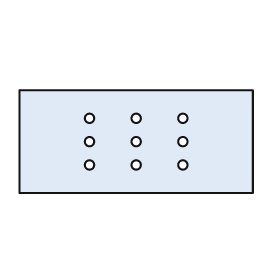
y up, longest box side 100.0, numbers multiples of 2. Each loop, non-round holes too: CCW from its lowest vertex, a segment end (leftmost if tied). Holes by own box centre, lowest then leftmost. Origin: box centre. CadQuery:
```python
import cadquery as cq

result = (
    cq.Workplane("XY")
    .moveTo(-50.0, -22.0)
    .lineTo(50.0, -22.0)
    .lineTo(50.0, 22.0)
    .lineTo(-50.0, 22.0)
    .close()
    .moveTo(-20.0, -10.0)
    .circle(2.0)
    .moveTo(0.0, -10.0)
    .circle(2.0)
    .moveTo(20.0, -10.0)
    .circle(2.0)
    .moveTo(-20.0, 0.0)
    .circle(2.0)
    .moveTo(0.0, 0.0)
    .circle(2.0)
    .moveTo(20.0, 0.0)
    .circle(2.0)
    .moveTo(-20.0, 10.0)
    .circle(2.0)
    .moveTo(0.0, 10.0)
    .circle(2.0)
    .moveTo(20.0, 10.0)
    .circle(2.0)
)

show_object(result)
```